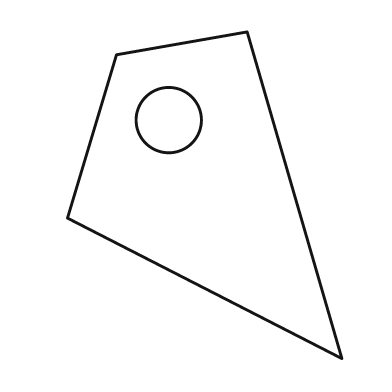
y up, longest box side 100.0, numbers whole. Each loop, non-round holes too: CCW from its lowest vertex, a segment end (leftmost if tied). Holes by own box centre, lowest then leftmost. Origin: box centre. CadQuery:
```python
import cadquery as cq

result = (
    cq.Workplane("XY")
    .moveTo(42.0, -50.0)
    .lineTo(13.0, 50.0)
    .lineTo(-27.0, 43.0)
    .lineTo(-42.0, -7.0)
    .close()
    .moveTo(-11.0, 23.0)
    .circle(10.0)
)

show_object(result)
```